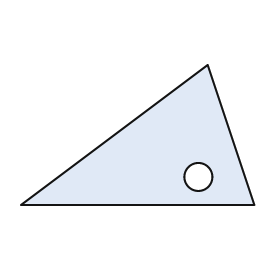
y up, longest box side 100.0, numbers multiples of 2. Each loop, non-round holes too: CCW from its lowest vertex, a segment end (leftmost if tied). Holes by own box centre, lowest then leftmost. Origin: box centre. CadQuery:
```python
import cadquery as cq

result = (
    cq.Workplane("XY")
    .moveTo(-50.0, -30.0)
    .lineTo(50.0, -30.0)
    .lineTo(30.0, 30.0)
    .close()
    .moveTo(26.0, -18.0)
    .circle(6.0)
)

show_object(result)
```